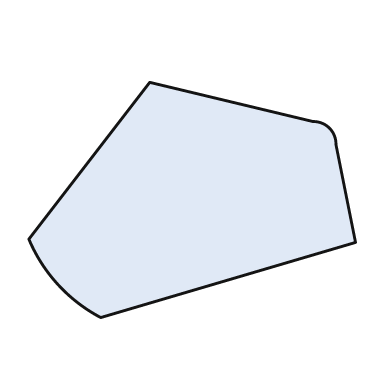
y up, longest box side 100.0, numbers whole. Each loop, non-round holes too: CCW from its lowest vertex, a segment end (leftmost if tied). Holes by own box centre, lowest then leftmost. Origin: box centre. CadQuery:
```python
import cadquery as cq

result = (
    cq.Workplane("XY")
    .moveTo(-28.0, -36.0)
    .lineTo(50.0, -13.0)
    .lineTo(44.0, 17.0)
    .threePointArc((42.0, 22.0), (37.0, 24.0))
    .lineTo(-13.0, 36.0)
    .lineTo(-50.0, -12.0)
    .threePointArc((-41.0, -26.0), (-28.0, -36.0))
    .close()
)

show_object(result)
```